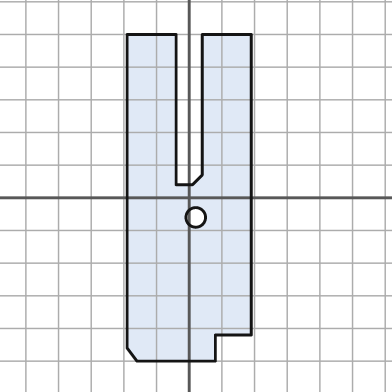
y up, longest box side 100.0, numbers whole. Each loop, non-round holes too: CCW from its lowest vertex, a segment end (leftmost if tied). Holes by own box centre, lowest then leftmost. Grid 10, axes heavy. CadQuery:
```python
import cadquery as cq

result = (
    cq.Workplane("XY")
    .moveTo(-16.0, -50.0)
    .lineTo(8.0, -50.0)
    .lineTo(8.0, -42.0)
    .lineTo(19.0, -42.0)
    .lineTo(19.0, 50.0)
    .lineTo(4.0, 50.0)
    .lineTo(4.0, 7.0)
    .lineTo(1.0, 4.0)
    .lineTo(-4.0, 4.0)
    .lineTo(-4.0, 50.0)
    .lineTo(-19.0, 50.0)
    .lineTo(-19.0, -46.0)
    .close()
    .moveTo(2.0, -6.0)
    .circle(3.0)
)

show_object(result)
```